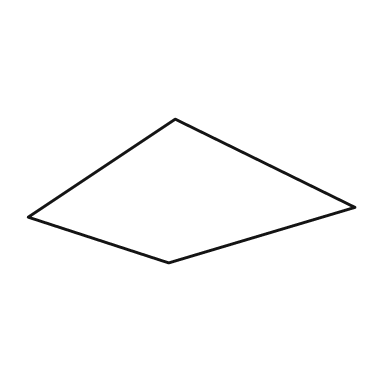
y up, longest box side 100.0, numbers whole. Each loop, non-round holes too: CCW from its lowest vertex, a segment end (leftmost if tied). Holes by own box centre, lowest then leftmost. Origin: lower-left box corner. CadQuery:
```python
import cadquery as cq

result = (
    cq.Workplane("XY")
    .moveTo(43.0, 0.0)
    .lineTo(100.0, 17.0)
    .lineTo(45.0, 44.0)
    .lineTo(0.0, 14.0)
    .close()
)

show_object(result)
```